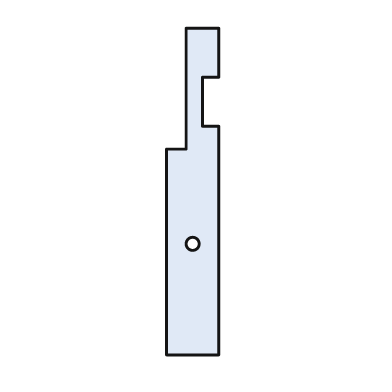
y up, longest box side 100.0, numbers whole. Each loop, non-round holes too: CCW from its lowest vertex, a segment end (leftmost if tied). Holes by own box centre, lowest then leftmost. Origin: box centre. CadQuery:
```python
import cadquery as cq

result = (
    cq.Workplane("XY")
    .moveTo(-8.0, -50.0)
    .lineTo(8.0, -50.0)
    .lineTo(8.0, 20.0)
    .lineTo(3.0, 20.0)
    .lineTo(3.0, 35.0)
    .lineTo(8.0, 35.0)
    .lineTo(8.0, 50.0)
    .lineTo(-2.0, 50.0)
    .lineTo(-2.0, 13.0)
    .lineTo(-8.0, 13.0)
    .close()
    .moveTo(0.0, -16.0)
    .circle(2.0)
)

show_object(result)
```